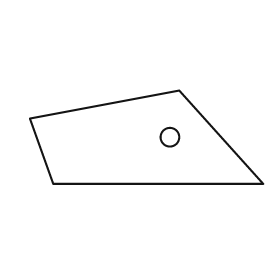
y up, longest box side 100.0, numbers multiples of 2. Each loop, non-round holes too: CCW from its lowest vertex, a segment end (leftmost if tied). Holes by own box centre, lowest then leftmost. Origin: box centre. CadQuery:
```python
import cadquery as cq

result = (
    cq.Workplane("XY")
    .moveTo(-40.0, -20.0)
    .lineTo(50.0, -20.0)
    .lineTo(14.0, 20.0)
    .lineTo(-50.0, 8.0)
    .close()
    .moveTo(10.0, 0.0)
    .circle(4.0)
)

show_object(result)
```